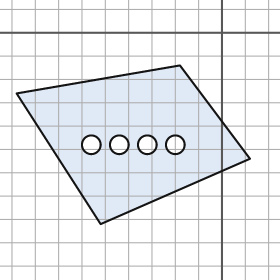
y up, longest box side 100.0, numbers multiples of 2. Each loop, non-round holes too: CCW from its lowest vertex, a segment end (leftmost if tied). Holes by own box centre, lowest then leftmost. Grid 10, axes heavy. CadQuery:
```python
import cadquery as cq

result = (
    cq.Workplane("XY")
    .moveTo(-52.0, -82.0)
    .lineTo(12.0, -54.0)
    .lineTo(-18.0, -14.0)
    .lineTo(-88.0, -26.0)
    .close()
    .moveTo(-56.0, -48.0)
    .circle(4.0)
    .moveTo(-44.0, -48.0)
    .circle(4.0)
    .moveTo(-32.0, -48.0)
    .circle(4.0)
    .moveTo(-20.0, -48.0)
    .circle(4.0)
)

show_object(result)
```